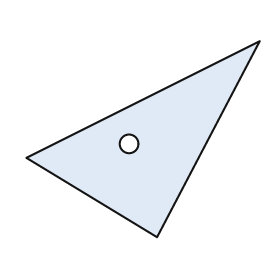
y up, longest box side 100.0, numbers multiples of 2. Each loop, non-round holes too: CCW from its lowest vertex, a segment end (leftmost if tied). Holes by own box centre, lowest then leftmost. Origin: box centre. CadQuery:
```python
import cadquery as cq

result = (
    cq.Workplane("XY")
    .moveTo(6.0, -42.0)
    .lineTo(50.0, 42.0)
    .lineTo(-50.0, -8.0)
    .close()
    .moveTo(-6.0, -2.0)
    .circle(4.0)
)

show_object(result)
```